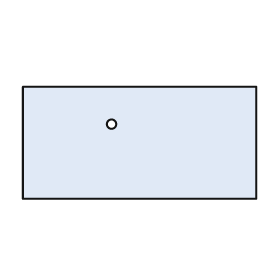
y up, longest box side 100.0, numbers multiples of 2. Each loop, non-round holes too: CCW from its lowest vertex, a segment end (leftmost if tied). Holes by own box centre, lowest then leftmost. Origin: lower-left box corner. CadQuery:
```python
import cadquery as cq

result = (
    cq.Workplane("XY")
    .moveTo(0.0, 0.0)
    .lineTo(100.0, 0.0)
    .lineTo(100.0, 48.0)
    .lineTo(0.0, 48.0)
    .close()
    .moveTo(38.0, 32.0)
    .circle(2.0)
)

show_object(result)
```